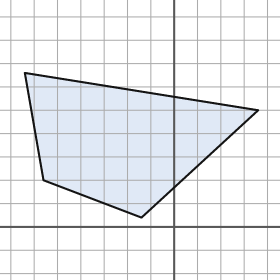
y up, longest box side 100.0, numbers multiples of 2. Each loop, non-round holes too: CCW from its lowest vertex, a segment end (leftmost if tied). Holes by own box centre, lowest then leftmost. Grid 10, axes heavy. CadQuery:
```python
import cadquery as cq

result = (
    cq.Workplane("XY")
    .moveTo(-14.0, 4.0)
    .lineTo(36.0, 50.0)
    .lineTo(-64.0, 66.0)
    .lineTo(-56.0, 20.0)
    .close()
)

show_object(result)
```